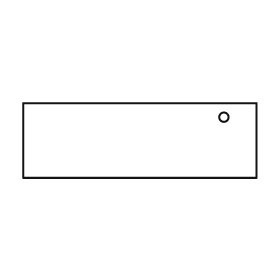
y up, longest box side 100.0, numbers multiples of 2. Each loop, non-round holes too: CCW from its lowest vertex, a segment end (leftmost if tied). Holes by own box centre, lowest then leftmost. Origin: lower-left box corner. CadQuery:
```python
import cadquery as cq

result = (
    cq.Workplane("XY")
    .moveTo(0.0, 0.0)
    .lineTo(100.0, 0.0)
    .lineTo(100.0, 32.0)
    .lineTo(0.0, 32.0)
    .close()
    .moveTo(86.0, 26.0)
    .circle(2.0)
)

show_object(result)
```